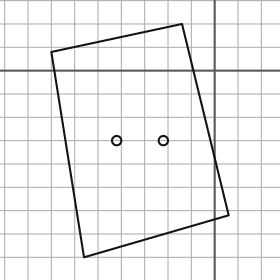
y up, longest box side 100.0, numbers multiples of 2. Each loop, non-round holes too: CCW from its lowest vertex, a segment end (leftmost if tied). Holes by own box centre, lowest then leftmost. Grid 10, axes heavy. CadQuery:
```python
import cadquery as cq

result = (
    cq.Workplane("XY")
    .moveTo(-56.0, -80.0)
    .lineTo(6.0, -62.0)
    .lineTo(-14.0, 20.0)
    .lineTo(-70.0, 8.0)
    .close()
    .moveTo(-42.0, -30.0)
    .circle(2.0)
    .moveTo(-22.0, -30.0)
    .circle(2.0)
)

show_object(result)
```